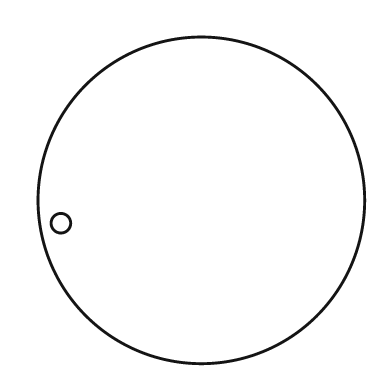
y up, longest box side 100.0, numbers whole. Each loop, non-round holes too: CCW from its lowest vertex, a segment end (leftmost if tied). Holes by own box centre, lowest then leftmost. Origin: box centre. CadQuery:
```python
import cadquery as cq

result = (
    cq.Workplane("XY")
    .moveTo(0.0, 0.0)
    .circle(50.0)
    .moveTo(-43.0, -7.0)
    .circle(3.0)
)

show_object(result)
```